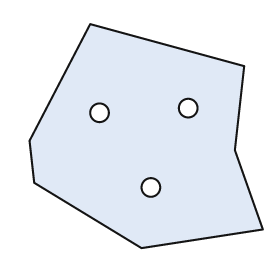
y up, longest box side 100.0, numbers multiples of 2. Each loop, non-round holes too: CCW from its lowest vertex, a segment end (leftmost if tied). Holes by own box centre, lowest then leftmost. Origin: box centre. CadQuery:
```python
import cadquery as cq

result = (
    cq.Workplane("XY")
    .moveTo(-2.0, -48.0)
    .lineTo(50.0, -40.0)
    .lineTo(38.0, -6.0)
    .lineTo(42.0, 30.0)
    .lineTo(-24.0, 48.0)
    .lineTo(-50.0, -2.0)
    .lineTo(-48.0, -20.0)
    .close()
    .moveTo(2.0, -22.0)
    .circle(4.0)
    .moveTo(-20.0, 10.0)
    .circle(4.0)
    .moveTo(18.0, 12.0)
    .circle(4.0)
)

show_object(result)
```